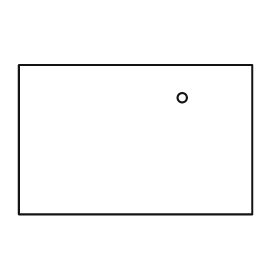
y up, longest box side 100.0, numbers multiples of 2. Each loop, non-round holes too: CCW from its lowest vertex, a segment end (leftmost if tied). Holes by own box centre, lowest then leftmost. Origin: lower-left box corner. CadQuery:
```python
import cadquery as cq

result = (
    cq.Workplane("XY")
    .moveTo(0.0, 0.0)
    .lineTo(100.0, 0.0)
    .lineTo(100.0, 64.0)
    .lineTo(0.0, 64.0)
    .close()
    .moveTo(70.0, 50.0)
    .circle(2.0)
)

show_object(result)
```